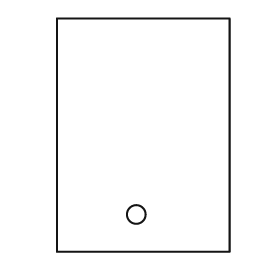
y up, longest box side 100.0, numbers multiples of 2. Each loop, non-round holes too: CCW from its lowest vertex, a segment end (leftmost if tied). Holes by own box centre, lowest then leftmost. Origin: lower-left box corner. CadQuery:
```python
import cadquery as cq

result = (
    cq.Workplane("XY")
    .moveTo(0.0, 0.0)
    .lineTo(74.0, 0.0)
    .lineTo(74.0, 100.0)
    .lineTo(0.0, 100.0)
    .close()
    .moveTo(34.0, 16.0)
    .circle(4.0)
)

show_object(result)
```